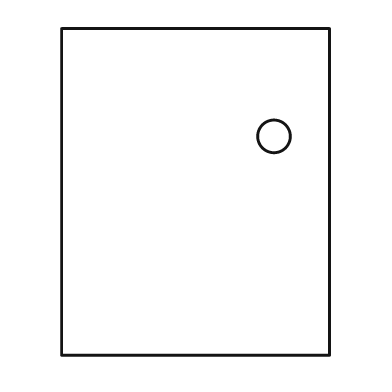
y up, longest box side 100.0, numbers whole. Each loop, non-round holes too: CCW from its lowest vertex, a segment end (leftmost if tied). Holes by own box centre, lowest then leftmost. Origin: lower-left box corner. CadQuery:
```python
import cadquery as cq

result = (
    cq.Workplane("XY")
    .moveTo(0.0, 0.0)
    .lineTo(82.0, 0.0)
    .lineTo(82.0, 100.0)
    .lineTo(0.0, 100.0)
    .close()
    .moveTo(65.0, 67.0)
    .circle(5.0)
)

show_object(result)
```